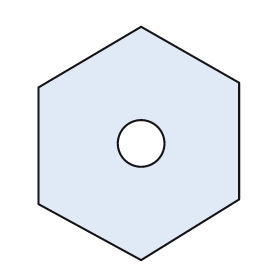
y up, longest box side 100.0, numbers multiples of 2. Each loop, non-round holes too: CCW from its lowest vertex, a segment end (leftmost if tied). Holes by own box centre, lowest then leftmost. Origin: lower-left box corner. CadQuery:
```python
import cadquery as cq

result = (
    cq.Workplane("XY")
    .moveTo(44.0, 0.0)
    .lineTo(86.0, 26.0)
    .lineTo(86.0, 76.0)
    .lineTo(44.0, 100.0)
    .lineTo(0.0, 74.0)
    .lineTo(0.0, 24.0)
    .close()
    .moveTo(44.0, 50.0)
    .circle(10.0)
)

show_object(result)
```